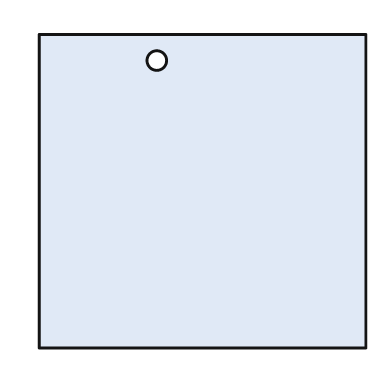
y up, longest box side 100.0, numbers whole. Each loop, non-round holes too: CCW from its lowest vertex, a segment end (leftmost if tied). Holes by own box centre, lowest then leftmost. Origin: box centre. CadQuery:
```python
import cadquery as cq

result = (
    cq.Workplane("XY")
    .moveTo(-50.0, -48.0)
    .lineTo(50.0, -48.0)
    .lineTo(50.0, 48.0)
    .lineTo(-50.0, 48.0)
    .close()
    .moveTo(-14.0, 40.0)
    .circle(3.0)
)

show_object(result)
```